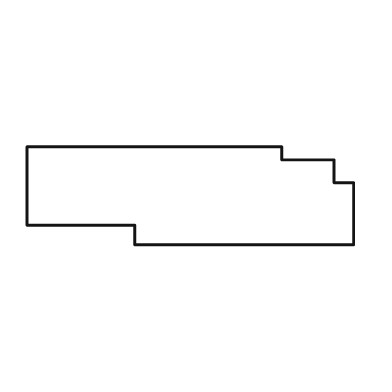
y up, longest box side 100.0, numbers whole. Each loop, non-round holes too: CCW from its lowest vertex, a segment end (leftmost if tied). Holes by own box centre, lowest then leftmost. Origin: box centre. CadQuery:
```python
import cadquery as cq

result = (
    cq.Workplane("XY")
    .moveTo(-17.0, -15.0)
    .lineTo(50.0, -15.0)
    .lineTo(50.0, 4.0)
    .lineTo(44.0, 4.0)
    .lineTo(44.0, 11.0)
    .lineTo(28.0, 11.0)
    .lineTo(28.0, 15.0)
    .lineTo(-50.0, 15.0)
    .lineTo(-50.0, -9.0)
    .lineTo(-17.0, -9.0)
    .close()
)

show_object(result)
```